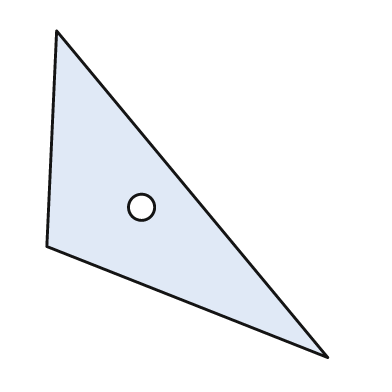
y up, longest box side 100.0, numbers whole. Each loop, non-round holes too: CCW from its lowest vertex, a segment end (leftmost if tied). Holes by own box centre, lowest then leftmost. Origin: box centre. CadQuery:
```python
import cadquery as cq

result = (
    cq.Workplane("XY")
    .moveTo(43.0, -50.0)
    .lineTo(-40.0, 50.0)
    .lineTo(-43.0, -16.0)
    .close()
    .moveTo(-14.0, -4.0)
    .circle(4.0)
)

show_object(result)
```